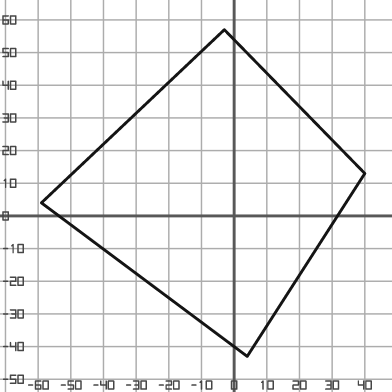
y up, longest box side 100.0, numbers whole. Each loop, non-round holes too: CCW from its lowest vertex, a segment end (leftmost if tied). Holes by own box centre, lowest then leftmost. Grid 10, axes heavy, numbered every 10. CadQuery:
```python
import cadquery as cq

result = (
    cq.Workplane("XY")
    .moveTo(4.0, -43.0)
    .lineTo(40.0, 13.0)
    .lineTo(-3.0, 57.0)
    .lineTo(-59.0, 4.0)
    .close()
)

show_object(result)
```